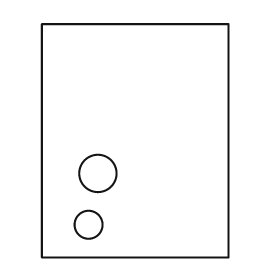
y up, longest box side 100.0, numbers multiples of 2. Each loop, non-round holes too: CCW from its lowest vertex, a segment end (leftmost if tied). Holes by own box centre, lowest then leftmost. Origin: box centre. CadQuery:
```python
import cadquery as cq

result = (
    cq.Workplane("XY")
    .moveTo(-40.0, -50.0)
    .lineTo(40.0, -50.0)
    .lineTo(40.0, 50.0)
    .lineTo(-40.0, 50.0)
    .close()
    .moveTo(-20.0, -36.0)
    .circle(6.0)
    .moveTo(-16.0, -14.0)
    .circle(8.0)
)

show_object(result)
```